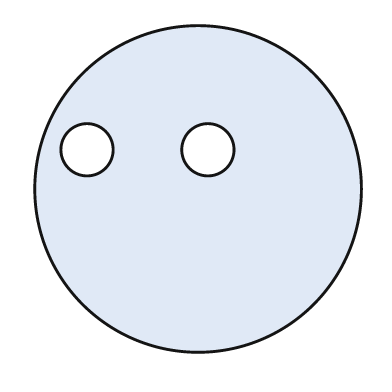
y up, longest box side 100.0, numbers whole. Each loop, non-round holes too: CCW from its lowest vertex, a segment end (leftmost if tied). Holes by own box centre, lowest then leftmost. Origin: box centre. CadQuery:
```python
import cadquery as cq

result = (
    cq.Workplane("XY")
    .moveTo(0.0, 0.0)
    .circle(50.0)
    .moveTo(-34.0, 12.0)
    .circle(8.0)
    .moveTo(3.0, 12.0)
    .circle(8.0)
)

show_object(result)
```